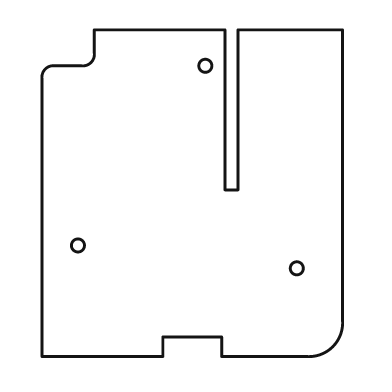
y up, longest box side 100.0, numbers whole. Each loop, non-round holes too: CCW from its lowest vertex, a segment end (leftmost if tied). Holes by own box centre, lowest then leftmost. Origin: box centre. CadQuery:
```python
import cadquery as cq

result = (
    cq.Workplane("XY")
    .moveTo(-46.0, -50.0)
    .lineTo(-9.0, -50.0)
    .lineTo(-9.0, -44.0)
    .lineTo(9.0, -44.0)
    .lineTo(9.0, -50.0)
    .lineTo(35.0, -50.0)
    .threePointArc((43.0, -47.0), (46.0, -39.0))
    .lineTo(46.0, 50.0)
    .lineTo(14.0, 50.0)
    .lineTo(14.0, 1.0)
    .lineTo(10.0, 1.0)
    .lineTo(10.0, 50.0)
    .lineTo(-30.0, 50.0)
    .lineTo(-30.0, 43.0)
    .threePointArc((-31.0, 40.0), (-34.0, 39.0))
    .lineTo(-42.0, 39.0)
    .threePointArc((-45.0, 38.0), (-46.0, 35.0))
    .close()
    .moveTo(32.0, -23.0)
    .circle(2.0)
    .moveTo(-35.0, -16.0)
    .circle(2.0)
    .moveTo(4.0, 39.0)
    .circle(2.0)
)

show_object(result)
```